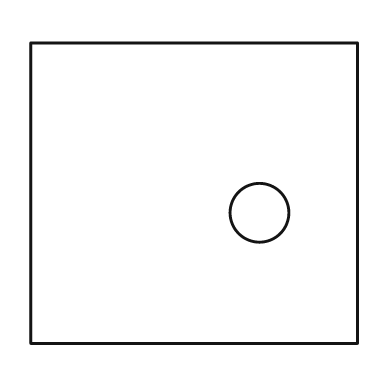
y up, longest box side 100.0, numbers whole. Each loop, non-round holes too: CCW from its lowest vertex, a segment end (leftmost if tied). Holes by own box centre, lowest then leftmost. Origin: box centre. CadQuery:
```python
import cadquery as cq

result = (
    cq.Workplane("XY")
    .moveTo(-50.0, -46.0)
    .lineTo(50.0, -46.0)
    .lineTo(50.0, 46.0)
    .lineTo(-50.0, 46.0)
    .close()
    .moveTo(20.0, -6.0)
    .circle(9.0)
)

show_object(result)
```